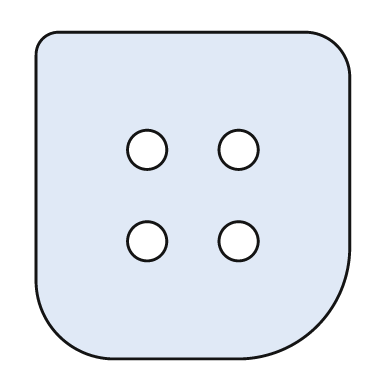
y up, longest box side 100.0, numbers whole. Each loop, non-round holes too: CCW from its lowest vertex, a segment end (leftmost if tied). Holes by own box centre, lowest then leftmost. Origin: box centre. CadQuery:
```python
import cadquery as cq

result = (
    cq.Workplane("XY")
    .moveTo(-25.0, -50.0)
    .lineTo(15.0, -50.0)
    .threePointArc((38.0, -40.0), (48.0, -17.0))
    .lineTo(48.0, 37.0)
    .threePointArc((44.0, 46.0), (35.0, 50.0))
    .lineTo(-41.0, 50.0)
    .threePointArc((-46.0, 48.0), (-48.0, 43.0))
    .lineTo(-48.0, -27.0)
    .threePointArc((-41.0, -43.0), (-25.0, -50.0))
    .close()
    .moveTo(-14.0, -14.0)
    .circle(6.0)
    .moveTo(14.0, -14.0)
    .circle(6.0)
    .moveTo(-14.0, 14.0)
    .circle(6.0)
    .moveTo(14.0, 14.0)
    .circle(6.0)
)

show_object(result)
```